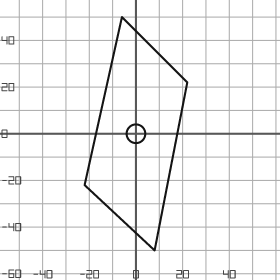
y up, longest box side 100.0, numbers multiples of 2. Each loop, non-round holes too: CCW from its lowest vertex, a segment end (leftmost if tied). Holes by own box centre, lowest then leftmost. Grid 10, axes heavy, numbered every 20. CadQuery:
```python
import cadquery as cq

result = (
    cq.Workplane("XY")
    .moveTo(8.0, -50.0)
    .lineTo(22.0, 22.0)
    .lineTo(-6.0, 50.0)
    .lineTo(-22.0, -22.0)
    .close()
    .moveTo(0.0, 0.0)
    .circle(4.0)
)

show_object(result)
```